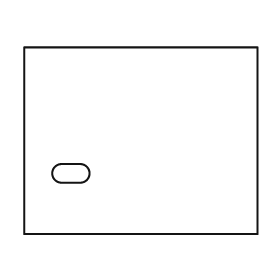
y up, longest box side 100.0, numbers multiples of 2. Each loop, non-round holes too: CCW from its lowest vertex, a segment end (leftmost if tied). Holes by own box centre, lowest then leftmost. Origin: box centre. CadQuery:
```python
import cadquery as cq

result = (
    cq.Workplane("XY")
    .moveTo(-50.0, -40.0)
    .lineTo(50.0, -40.0)
    .lineTo(50.0, 40.0)
    .lineTo(-50.0, 40.0)
    .close()
    .moveTo(-34.0, -18.0)
    .lineTo(-26.0, -18.0)
    .threePointArc((-22.0, -14.0), (-26.0, -10.0))
    .lineTo(-34.0, -10.0)
    .threePointArc((-38.0, -14.0), (-34.0, -18.0))
    .close()
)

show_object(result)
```